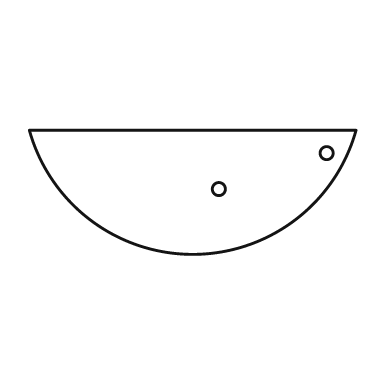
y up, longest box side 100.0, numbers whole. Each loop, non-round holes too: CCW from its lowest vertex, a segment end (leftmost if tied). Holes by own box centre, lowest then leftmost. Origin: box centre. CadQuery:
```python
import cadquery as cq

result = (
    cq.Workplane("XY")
    .moveTo(-50.0, 19.0)
    .threePointArc((0.0, -19.0), (50.0, 19.0))
    .close()
    .moveTo(8.0, 1.0)
    .circle(2.0)
    .moveTo(41.0, 12.0)
    .circle(2.0)
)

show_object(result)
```